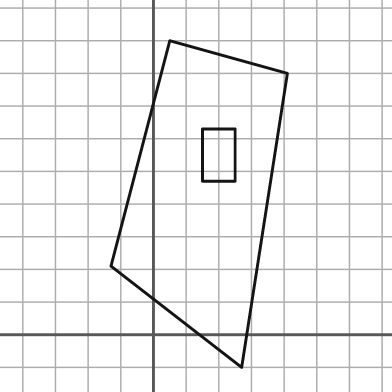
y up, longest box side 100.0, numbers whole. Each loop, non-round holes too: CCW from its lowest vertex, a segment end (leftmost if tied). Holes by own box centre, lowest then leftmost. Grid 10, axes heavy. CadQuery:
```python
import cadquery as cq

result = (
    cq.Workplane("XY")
    .moveTo(27.0, -10.0)
    .lineTo(41.0, 80.0)
    .lineTo(5.0, 90.0)
    .lineTo(-13.0, 21.0)
    .close()
    .moveTo(15.0, 47.0)
    .lineTo(25.0, 47.0)
    .lineTo(25.0, 63.0)
    .lineTo(15.0, 63.0)
    .close()
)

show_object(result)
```